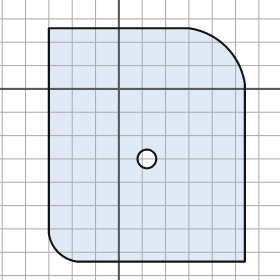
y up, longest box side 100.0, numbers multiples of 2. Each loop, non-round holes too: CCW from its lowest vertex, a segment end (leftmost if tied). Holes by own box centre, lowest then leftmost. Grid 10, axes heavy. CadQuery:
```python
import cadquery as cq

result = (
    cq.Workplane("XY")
    .moveTo(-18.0, -74.0)
    .lineTo(54.0, -74.0)
    .lineTo(54.0, 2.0)
    .threePointArc((46.0, 18.0), (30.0, 26.0))
    .lineTo(-30.0, 26.0)
    .lineTo(-30.0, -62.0)
    .threePointArc((-26.0, -70.0), (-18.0, -74.0))
    .close()
    .moveTo(12.0, -30.0)
    .circle(4.0)
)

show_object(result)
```